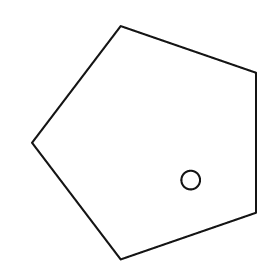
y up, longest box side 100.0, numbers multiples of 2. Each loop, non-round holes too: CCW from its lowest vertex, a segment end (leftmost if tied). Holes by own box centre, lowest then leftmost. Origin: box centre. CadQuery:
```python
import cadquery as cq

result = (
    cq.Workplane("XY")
    .moveTo(-10.0, -50.0)
    .lineTo(48.0, -30.0)
    .lineTo(48.0, 30.0)
    .lineTo(-10.0, 50.0)
    .lineTo(-48.0, 0.0)
    .close()
    .moveTo(20.0, -16.0)
    .circle(4.0)
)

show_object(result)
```